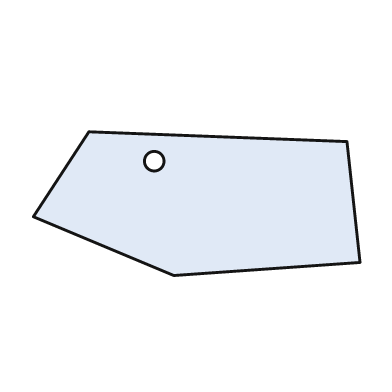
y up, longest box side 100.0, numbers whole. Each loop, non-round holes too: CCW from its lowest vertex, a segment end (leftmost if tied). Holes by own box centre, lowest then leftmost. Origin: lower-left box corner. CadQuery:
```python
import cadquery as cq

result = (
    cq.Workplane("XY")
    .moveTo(43.0, 0.0)
    .lineTo(100.0, 4.0)
    .lineTo(96.0, 41.0)
    .lineTo(17.0, 44.0)
    .lineTo(0.0, 18.0)
    .close()
    .moveTo(37.0, 35.0)
    .circle(3.0)
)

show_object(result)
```